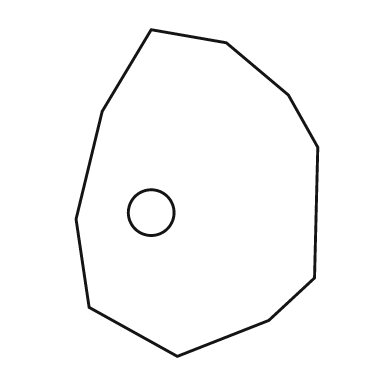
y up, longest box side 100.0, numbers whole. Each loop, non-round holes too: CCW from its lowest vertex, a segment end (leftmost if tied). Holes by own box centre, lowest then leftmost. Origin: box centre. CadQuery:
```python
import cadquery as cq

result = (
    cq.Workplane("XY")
    .moveTo(-6.0, -50.0)
    .lineTo(22.0, -39.0)
    .lineTo(36.0, -26.0)
    .lineTo(37.0, 14.0)
    .lineTo(28.0, 30.0)
    .lineTo(9.0, 46.0)
    .lineTo(-14.0, 50.0)
    .lineTo(-29.0, 25.0)
    .lineTo(-37.0, -8.0)
    .lineTo(-33.0, -35.0)
    .close()
    .moveTo(-14.0, -6.0)
    .circle(7.0)
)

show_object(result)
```